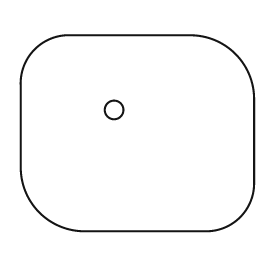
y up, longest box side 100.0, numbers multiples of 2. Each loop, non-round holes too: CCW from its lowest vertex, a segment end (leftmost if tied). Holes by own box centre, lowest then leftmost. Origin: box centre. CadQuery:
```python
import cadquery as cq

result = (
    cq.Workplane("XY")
    .moveTo(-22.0, -42.0)
    .lineTo(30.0, -42.0)
    .threePointArc((44.0, -36.0), (50.0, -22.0))
    .lineTo(50.0, 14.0)
    .threePointArc((42.0, 34.0), (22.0, 42.0))
    .lineTo(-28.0, 42.0)
    .threePointArc((-44.0, 36.0), (-50.0, 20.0))
    .lineTo(-50.0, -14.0)
    .threePointArc((-42.0, -34.0), (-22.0, -42.0))
    .close()
    .moveTo(-10.0, 10.0)
    .circle(4.0)
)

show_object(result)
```